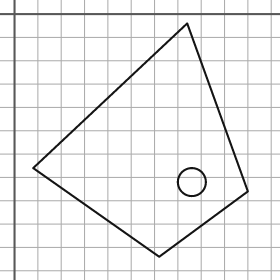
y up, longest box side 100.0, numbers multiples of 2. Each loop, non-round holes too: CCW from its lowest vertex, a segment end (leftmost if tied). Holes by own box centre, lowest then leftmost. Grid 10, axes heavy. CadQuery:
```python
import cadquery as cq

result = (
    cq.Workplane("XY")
    .moveTo(62.0, -104.0)
    .lineTo(100.0, -76.0)
    .lineTo(74.0, -4.0)
    .lineTo(8.0, -66.0)
    .close()
    .moveTo(76.0, -72.0)
    .circle(6.0)
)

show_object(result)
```